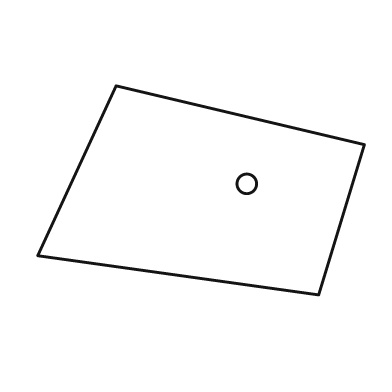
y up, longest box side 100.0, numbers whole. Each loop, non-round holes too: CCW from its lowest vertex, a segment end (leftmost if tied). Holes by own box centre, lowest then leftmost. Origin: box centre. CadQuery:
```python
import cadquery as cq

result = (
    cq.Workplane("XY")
    .moveTo(36.0, -32.0)
    .lineTo(50.0, 14.0)
    .lineTo(-26.0, 32.0)
    .lineTo(-50.0, -20.0)
    .close()
    .moveTo(14.0, 2.0)
    .circle(3.0)
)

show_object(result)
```